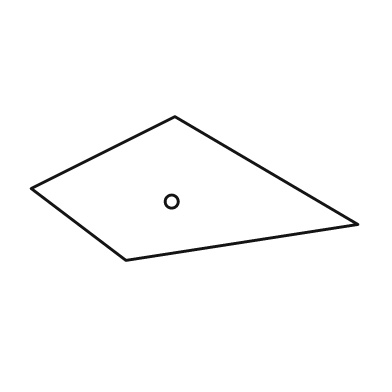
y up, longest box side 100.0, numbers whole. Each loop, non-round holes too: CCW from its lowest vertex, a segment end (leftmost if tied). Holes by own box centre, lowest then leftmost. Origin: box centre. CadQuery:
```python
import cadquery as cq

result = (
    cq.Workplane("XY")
    .moveTo(-21.0, -22.0)
    .lineTo(50.0, -11.0)
    .lineTo(-6.0, 22.0)
    .lineTo(-50.0, 0.0)
    .close()
    .moveTo(-7.0, -4.0)
    .circle(2.0)
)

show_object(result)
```